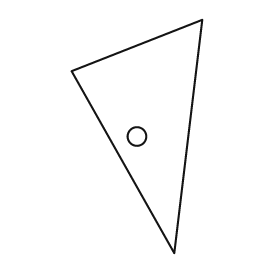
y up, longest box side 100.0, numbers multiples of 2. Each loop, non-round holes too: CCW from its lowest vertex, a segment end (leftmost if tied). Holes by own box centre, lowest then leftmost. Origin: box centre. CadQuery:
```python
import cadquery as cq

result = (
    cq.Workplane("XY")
    .moveTo(16.0, -50.0)
    .lineTo(28.0, 50.0)
    .lineTo(-28.0, 28.0)
    .close()
    .moveTo(0.0, 0.0)
    .circle(4.0)
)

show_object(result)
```